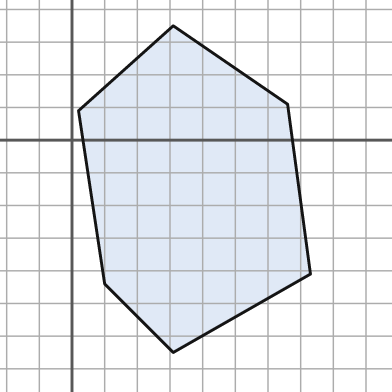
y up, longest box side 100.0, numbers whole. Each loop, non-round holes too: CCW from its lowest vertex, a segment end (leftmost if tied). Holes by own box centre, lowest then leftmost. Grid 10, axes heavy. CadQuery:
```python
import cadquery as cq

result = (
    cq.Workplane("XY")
    .moveTo(31.0, -65.0)
    .lineTo(73.0, -41.0)
    .lineTo(66.0, 11.0)
    .lineTo(31.0, 35.0)
    .lineTo(2.0, 9.0)
    .lineTo(10.0, -44.0)
    .close()
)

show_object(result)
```